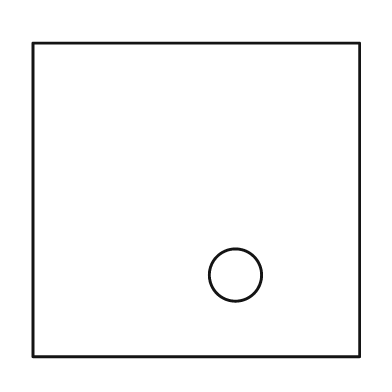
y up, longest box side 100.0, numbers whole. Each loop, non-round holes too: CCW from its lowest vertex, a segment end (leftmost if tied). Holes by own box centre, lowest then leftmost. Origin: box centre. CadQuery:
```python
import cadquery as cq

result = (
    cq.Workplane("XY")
    .moveTo(-50.0, -48.0)
    .lineTo(50.0, -48.0)
    .lineTo(50.0, 48.0)
    .lineTo(-50.0, 48.0)
    .close()
    .moveTo(12.0, -23.0)
    .circle(8.0)
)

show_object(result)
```